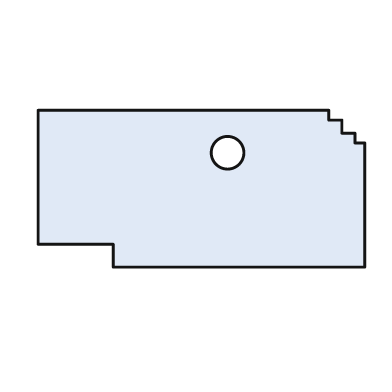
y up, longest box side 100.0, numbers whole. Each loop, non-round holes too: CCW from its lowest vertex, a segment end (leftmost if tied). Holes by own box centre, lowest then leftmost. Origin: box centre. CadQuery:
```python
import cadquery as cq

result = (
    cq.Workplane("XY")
    .moveTo(-27.0, -24.0)
    .lineTo(50.0, -24.0)
    .lineTo(50.0, 14.0)
    .lineTo(47.0, 14.0)
    .lineTo(47.0, 17.0)
    .lineTo(43.0, 17.0)
    .lineTo(43.0, 21.0)
    .lineTo(39.0, 21.0)
    .lineTo(39.0, 24.0)
    .lineTo(-50.0, 24.0)
    .lineTo(-50.0, -17.0)
    .lineTo(-27.0, -17.0)
    .close()
    .moveTo(8.0, 11.0)
    .circle(5.0)
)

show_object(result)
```